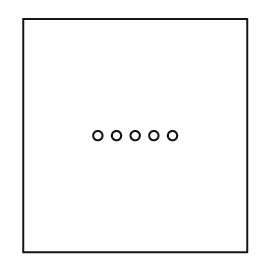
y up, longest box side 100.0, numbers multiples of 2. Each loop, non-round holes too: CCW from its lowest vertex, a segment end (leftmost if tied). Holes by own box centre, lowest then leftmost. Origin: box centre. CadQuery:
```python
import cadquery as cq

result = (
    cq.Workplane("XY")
    .moveTo(-48.0, -50.0)
    .lineTo(48.0, -50.0)
    .lineTo(48.0, 50.0)
    .lineTo(-48.0, 50.0)
    .close()
    .moveTo(-16.0, 0.0)
    .circle(2.0)
    .moveTo(-8.0, 0.0)
    .circle(2.0)
    .moveTo(0.0, 0.0)
    .circle(2.0)
    .moveTo(8.0, 0.0)
    .circle(2.0)
    .moveTo(16.0, 0.0)
    .circle(2.0)
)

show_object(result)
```